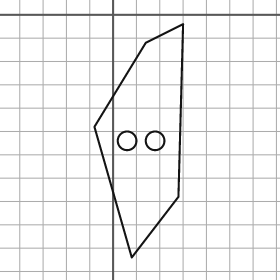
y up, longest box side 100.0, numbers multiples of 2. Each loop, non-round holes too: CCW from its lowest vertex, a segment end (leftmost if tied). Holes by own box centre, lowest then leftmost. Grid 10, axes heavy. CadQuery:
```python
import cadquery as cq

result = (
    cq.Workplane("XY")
    .moveTo(8.0, -104.0)
    .lineTo(28.0, -78.0)
    .lineTo(30.0, -4.0)
    .lineTo(14.0, -12.0)
    .lineTo(-8.0, -48.0)
    .close()
    .moveTo(6.0, -54.0)
    .circle(4.0)
    .moveTo(18.0, -54.0)
    .circle(4.0)
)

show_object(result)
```